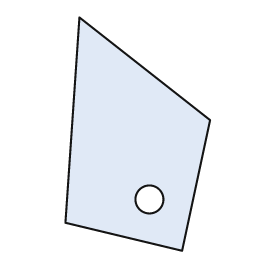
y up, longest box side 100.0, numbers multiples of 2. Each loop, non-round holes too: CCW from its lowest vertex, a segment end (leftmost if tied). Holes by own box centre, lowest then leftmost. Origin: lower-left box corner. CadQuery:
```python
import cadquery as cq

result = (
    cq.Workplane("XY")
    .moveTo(50.0, 0.0)
    .lineTo(62.0, 56.0)
    .lineTo(6.0, 100.0)
    .lineTo(0.0, 12.0)
    .close()
    .moveTo(36.0, 22.0)
    .circle(6.0)
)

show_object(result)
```